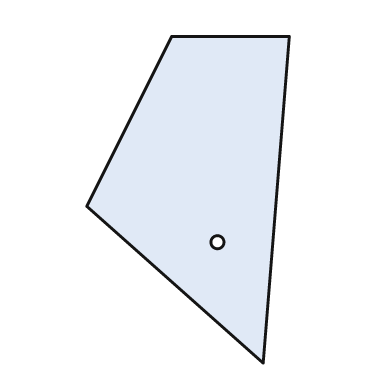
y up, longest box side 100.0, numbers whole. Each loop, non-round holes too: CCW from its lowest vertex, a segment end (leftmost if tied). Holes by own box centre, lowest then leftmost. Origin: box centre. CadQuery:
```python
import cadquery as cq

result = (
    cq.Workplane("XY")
    .moveTo(23.0, -50.0)
    .lineTo(31.0, 50.0)
    .lineTo(-5.0, 50.0)
    .lineTo(-31.0, -2.0)
    .close()
    .moveTo(9.0, -13.0)
    .circle(2.0)
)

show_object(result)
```